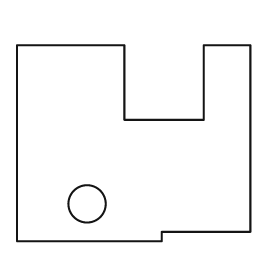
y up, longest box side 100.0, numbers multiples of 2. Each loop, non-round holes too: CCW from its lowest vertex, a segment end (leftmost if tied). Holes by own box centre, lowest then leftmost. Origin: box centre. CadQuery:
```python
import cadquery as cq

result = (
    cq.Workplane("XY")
    .moveTo(-50.0, -42.0)
    .lineTo(12.0, -42.0)
    .lineTo(12.0, -38.0)
    .lineTo(50.0, -38.0)
    .lineTo(50.0, 42.0)
    .lineTo(30.0, 42.0)
    .lineTo(30.0, 10.0)
    .lineTo(-4.0, 10.0)
    .lineTo(-4.0, 42.0)
    .lineTo(-50.0, 42.0)
    .close()
    .moveTo(-20.0, -26.0)
    .circle(8.0)
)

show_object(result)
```